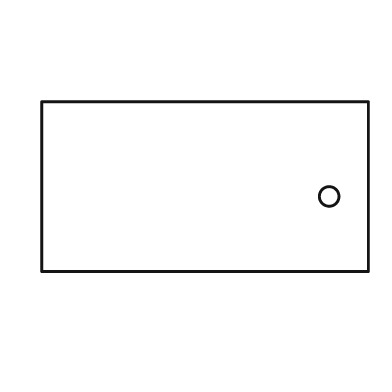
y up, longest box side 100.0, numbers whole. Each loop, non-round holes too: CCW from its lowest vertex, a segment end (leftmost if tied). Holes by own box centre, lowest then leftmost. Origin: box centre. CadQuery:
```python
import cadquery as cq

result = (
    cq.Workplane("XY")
    .moveTo(-50.0, -26.0)
    .lineTo(50.0, -26.0)
    .lineTo(50.0, 26.0)
    .lineTo(-50.0, 26.0)
    .close()
    .moveTo(38.0, -3.0)
    .circle(3.0)
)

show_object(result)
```